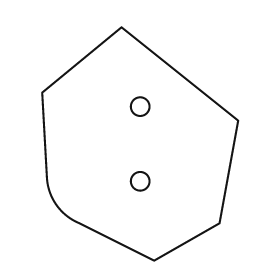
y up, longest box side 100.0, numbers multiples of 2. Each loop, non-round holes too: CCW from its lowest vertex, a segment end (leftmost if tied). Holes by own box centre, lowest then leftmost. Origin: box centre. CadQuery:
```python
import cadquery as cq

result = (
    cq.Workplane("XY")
    .moveTo(6.0, -50.0)
    .lineTo(34.0, -34.0)
    .lineTo(42.0, 10.0)
    .lineTo(-8.0, 50.0)
    .lineTo(-42.0, 22.0)
    .lineTo(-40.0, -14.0)
    .threePointArc((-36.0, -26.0), (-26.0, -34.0))
    .close()
    .moveTo(0.0, -16.0)
    .circle(4.0)
    .moveTo(0.0, 16.0)
    .circle(4.0)
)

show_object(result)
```